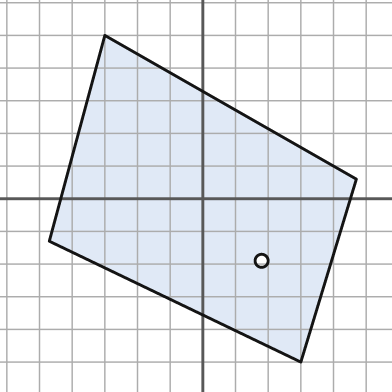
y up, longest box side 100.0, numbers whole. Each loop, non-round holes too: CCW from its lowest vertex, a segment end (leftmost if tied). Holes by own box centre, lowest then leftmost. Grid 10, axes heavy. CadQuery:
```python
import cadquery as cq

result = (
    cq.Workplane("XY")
    .moveTo(30.0, -50.0)
    .lineTo(47.0, 6.0)
    .lineTo(-30.0, 50.0)
    .lineTo(-47.0, -13.0)
    .close()
    .moveTo(18.0, -19.0)
    .circle(2.0)
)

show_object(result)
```